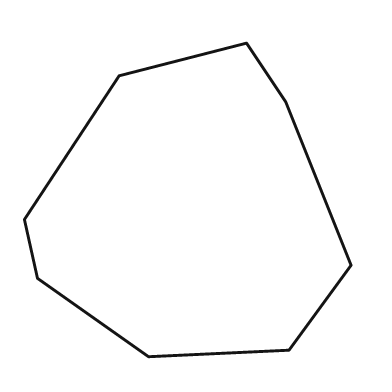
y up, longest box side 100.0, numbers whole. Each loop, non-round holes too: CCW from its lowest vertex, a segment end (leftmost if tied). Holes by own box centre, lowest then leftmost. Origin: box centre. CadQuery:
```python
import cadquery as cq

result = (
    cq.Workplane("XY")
    .moveTo(-12.0, -48.0)
    .lineTo(31.0, -46.0)
    .lineTo(50.0, -20.0)
    .lineTo(30.0, 30.0)
    .lineTo(18.0, 48.0)
    .lineTo(-21.0, 38.0)
    .lineTo(-50.0, -6.0)
    .lineTo(-46.0, -24.0)
    .close()
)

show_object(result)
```